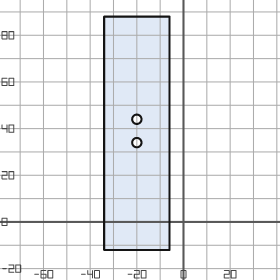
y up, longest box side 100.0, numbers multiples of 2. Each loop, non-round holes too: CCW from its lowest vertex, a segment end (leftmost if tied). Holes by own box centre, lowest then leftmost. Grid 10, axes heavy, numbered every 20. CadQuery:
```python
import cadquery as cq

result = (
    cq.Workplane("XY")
    .moveTo(-34.0, -12.0)
    .lineTo(-6.0, -12.0)
    .lineTo(-6.0, 88.0)
    .lineTo(-34.0, 88.0)
    .close()
    .moveTo(-20.0, 34.0)
    .circle(2.0)
    .moveTo(-20.0, 44.0)
    .circle(2.0)
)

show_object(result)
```